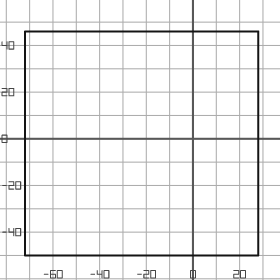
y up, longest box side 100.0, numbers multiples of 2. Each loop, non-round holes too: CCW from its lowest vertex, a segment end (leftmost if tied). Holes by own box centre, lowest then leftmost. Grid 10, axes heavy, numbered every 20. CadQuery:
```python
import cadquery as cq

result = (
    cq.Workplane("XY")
    .moveTo(-72.0, -50.0)
    .lineTo(28.0, -50.0)
    .lineTo(28.0, 46.0)
    .lineTo(-72.0, 46.0)
    .close()
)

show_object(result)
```